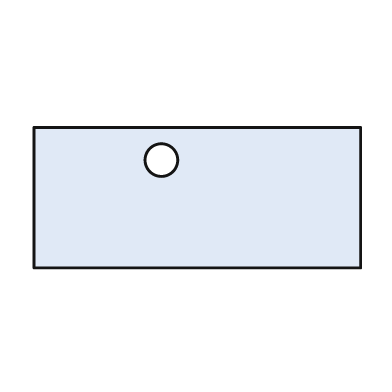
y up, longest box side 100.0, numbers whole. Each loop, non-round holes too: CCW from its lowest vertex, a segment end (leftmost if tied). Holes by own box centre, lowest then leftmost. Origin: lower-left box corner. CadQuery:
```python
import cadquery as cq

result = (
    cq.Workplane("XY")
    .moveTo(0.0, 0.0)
    .lineTo(100.0, 0.0)
    .lineTo(100.0, 43.0)
    .lineTo(0.0, 43.0)
    .close()
    .moveTo(39.0, 33.0)
    .circle(5.0)
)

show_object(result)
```